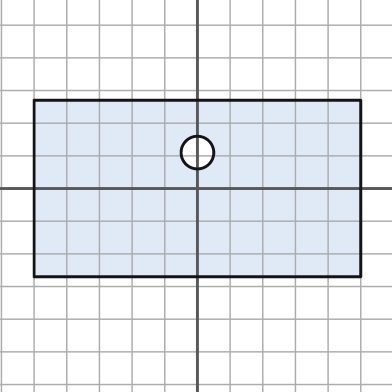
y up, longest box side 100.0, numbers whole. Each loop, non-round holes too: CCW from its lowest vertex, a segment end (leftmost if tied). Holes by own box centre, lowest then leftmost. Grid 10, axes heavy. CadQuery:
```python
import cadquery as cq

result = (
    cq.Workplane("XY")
    .moveTo(-50.0, -27.0)
    .lineTo(50.0, -27.0)
    .lineTo(50.0, 27.0)
    .lineTo(-50.0, 27.0)
    .close()
    .moveTo(0.0, 11.0)
    .circle(5.0)
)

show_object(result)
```